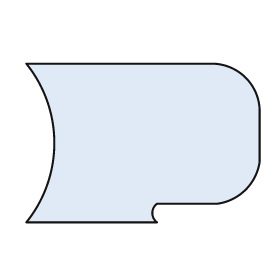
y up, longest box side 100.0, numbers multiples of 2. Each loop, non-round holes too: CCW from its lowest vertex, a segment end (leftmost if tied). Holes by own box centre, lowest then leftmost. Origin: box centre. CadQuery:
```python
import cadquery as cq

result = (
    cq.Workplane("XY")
    .moveTo(-50.0, -34.0)
    .lineTo(6.0, -34.0)
    .threePointArc((4.0, -30.0), (6.0, -26.0))
    .lineTo(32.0, -26.0)
    .threePointArc((44.0, -20.0), (50.0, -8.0))
    .lineTo(50.0, 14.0)
    .threePointArc((44.0, 28.0), (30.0, 34.0))
    .lineTo(-50.0, 34.0)
    .threePointArc((-38.0, 0.0), (-50.0, -34.0))
    .close()
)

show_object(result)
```